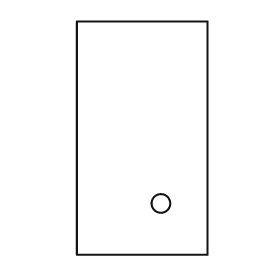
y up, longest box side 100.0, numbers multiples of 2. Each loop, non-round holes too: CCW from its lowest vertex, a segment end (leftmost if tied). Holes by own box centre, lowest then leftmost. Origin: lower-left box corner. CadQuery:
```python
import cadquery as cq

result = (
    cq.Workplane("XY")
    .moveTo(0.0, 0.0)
    .lineTo(56.0, 0.0)
    .lineTo(56.0, 100.0)
    .lineTo(0.0, 100.0)
    .close()
    .moveTo(36.0, 22.0)
    .circle(4.0)
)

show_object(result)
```